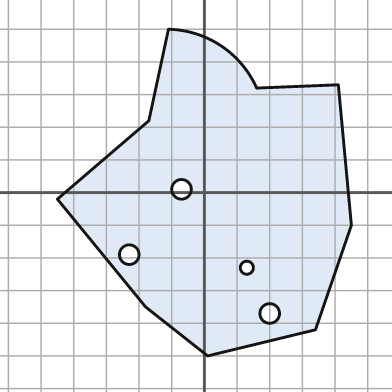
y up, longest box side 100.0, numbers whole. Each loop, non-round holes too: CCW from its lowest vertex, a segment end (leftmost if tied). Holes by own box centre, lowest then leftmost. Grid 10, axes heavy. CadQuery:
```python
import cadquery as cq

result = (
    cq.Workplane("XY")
    .moveTo(1.0, -50.0)
    .lineTo(34.0, -42.0)
    .lineTo(45.0, -10.0)
    .lineTo(41.0, 33.0)
    .lineTo(16.0, 32.0)
    .threePointArc((5.0, 45.0), (-11.0, 50.0))
    .lineTo(-17.0, 22.0)
    .lineTo(-45.0, -2.0)
    .lineTo(-18.0, -35.0)
    .close()
    .moveTo(20.0, -37.0)
    .circle(3.0)
    .moveTo(13.0, -23.0)
    .circle(2.0)
    .moveTo(-23.0, -19.0)
    .circle(3.0)
    .moveTo(-7.0, 1.0)
    .circle(3.0)
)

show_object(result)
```